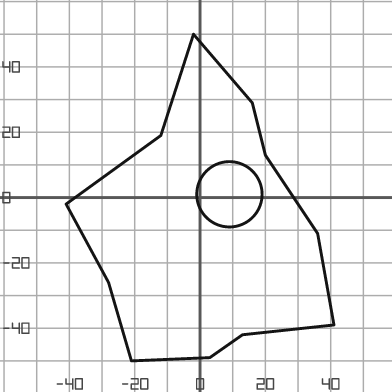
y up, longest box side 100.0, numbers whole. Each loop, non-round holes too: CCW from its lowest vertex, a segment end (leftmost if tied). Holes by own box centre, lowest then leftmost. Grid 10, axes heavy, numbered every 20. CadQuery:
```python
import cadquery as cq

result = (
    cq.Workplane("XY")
    .moveTo(-21.0, -50.0)
    .lineTo(3.0, -49.0)
    .lineTo(13.0, -42.0)
    .lineTo(41.0, -39.0)
    .lineTo(36.0, -11.0)
    .lineTo(20.0, 13.0)
    .lineTo(16.0, 29.0)
    .lineTo(-2.0, 50.0)
    .lineTo(-12.0, 19.0)
    .lineTo(-41.0, -2.0)
    .lineTo(-28.0, -26.0)
    .close()
    .moveTo(9.0, 1.0)
    .circle(10.0)
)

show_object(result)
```